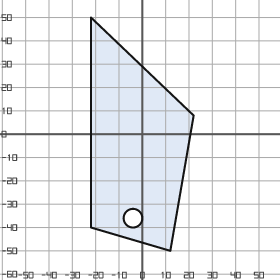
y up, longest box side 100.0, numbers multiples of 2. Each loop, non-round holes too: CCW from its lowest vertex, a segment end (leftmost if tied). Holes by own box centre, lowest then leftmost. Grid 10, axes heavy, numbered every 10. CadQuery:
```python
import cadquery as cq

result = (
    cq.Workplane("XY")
    .moveTo(12.0, -50.0)
    .lineTo(22.0, 8.0)
    .lineTo(-22.0, 50.0)
    .lineTo(-22.0, -40.0)
    .close()
    .moveTo(-4.0, -36.0)
    .circle(4.0)
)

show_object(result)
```